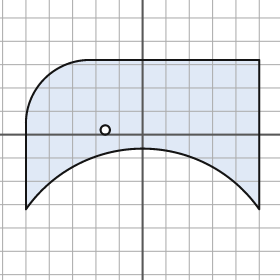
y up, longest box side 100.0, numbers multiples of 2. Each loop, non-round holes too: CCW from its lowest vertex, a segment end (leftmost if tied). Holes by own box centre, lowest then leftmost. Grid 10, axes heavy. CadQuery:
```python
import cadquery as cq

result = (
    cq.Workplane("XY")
    .moveTo(-50.0, -32.0)
    .threePointArc((0.0, -6.0), (50.0, -32.0))
    .lineTo(50.0, 32.0)
    .lineTo(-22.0, 32.0)
    .threePointArc((-42.0, 24.0), (-50.0, 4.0))
    .close()
    .moveTo(-16.0, 2.0)
    .circle(2.0)
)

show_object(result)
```